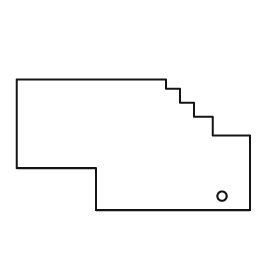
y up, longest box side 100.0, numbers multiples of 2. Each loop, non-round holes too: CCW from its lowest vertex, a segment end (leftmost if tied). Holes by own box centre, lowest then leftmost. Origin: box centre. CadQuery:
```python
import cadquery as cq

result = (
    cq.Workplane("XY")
    .moveTo(-16.0, -28.0)
    .lineTo(50.0, -28.0)
    .lineTo(50.0, 4.0)
    .lineTo(34.0, 4.0)
    .lineTo(34.0, 12.0)
    .lineTo(26.0, 12.0)
    .lineTo(26.0, 18.0)
    .lineTo(20.0, 18.0)
    .lineTo(20.0, 24.0)
    .lineTo(14.0, 24.0)
    .lineTo(14.0, 28.0)
    .lineTo(-50.0, 28.0)
    .lineTo(-50.0, -10.0)
    .lineTo(-16.0, -10.0)
    .close()
    .moveTo(38.0, -22.0)
    .circle(2.0)
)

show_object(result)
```